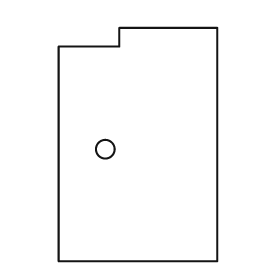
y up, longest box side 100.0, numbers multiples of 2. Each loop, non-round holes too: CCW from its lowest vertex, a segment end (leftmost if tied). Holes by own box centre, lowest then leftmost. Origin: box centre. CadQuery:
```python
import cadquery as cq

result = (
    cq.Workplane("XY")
    .moveTo(-34.0, -50.0)
    .lineTo(34.0, -50.0)
    .lineTo(34.0, 50.0)
    .lineTo(-8.0, 50.0)
    .lineTo(-8.0, 42.0)
    .lineTo(-34.0, 42.0)
    .close()
    .moveTo(-14.0, -2.0)
    .circle(4.0)
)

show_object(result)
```